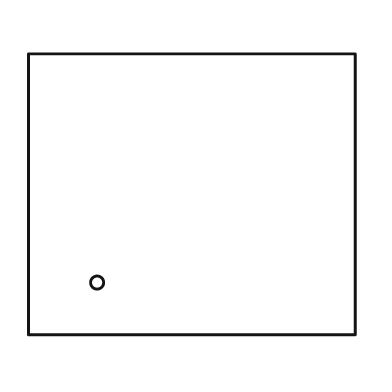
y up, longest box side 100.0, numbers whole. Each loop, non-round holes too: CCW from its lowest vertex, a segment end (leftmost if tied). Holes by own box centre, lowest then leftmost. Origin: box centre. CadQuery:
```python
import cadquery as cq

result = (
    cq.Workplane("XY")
    .moveTo(-50.0, -43.0)
    .lineTo(50.0, -43.0)
    .lineTo(50.0, 43.0)
    .lineTo(-50.0, 43.0)
    .close()
    .moveTo(-29.0, -27.0)
    .circle(2.0)
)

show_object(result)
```